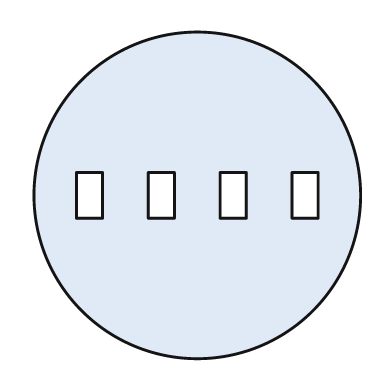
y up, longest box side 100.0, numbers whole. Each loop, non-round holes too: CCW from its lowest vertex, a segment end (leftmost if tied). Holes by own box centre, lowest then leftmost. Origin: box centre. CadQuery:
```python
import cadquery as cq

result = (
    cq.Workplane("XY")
    .moveTo(0.0, 0.0)
    .circle(50.0)
    .moveTo(-37.0, -7.0)
    .lineTo(-29.0, -7.0)
    .lineTo(-29.0, 7.0)
    .lineTo(-37.0, 7.0)
    .close()
    .moveTo(-15.0, -7.0)
    .lineTo(-7.0, -7.0)
    .lineTo(-7.0, 7.0)
    .lineTo(-15.0, 7.0)
    .close()
    .moveTo(7.0, -7.0)
    .lineTo(15.0, -7.0)
    .lineTo(15.0, 7.0)
    .lineTo(7.0, 7.0)
    .close()
    .moveTo(29.0, -7.0)
    .lineTo(37.0, -7.0)
    .lineTo(37.0, 7.0)
    .lineTo(29.0, 7.0)
    .close()
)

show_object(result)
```